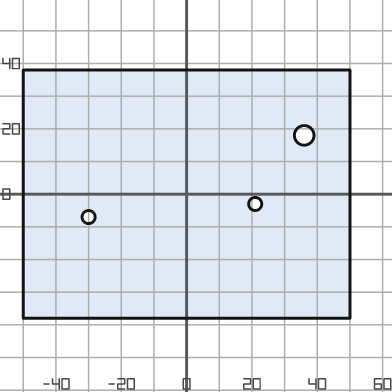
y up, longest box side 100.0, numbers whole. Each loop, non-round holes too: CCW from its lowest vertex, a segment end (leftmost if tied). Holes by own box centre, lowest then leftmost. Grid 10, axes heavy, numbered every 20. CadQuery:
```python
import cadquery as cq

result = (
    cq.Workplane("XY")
    .moveTo(-50.0, -38.0)
    .lineTo(50.0, -38.0)
    .lineTo(50.0, 38.0)
    .lineTo(-50.0, 38.0)
    .close()
    .moveTo(-30.0, -7.0)
    .circle(2.0)
    .moveTo(21.0, -3.0)
    .circle(2.0)
    .moveTo(36.0, 18.0)
    .circle(3.0)
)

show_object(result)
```